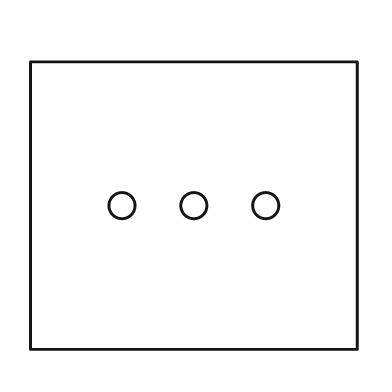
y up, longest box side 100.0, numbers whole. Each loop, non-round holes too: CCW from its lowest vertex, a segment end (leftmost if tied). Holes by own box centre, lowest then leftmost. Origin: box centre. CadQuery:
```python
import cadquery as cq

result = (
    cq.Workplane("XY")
    .moveTo(-50.0, -44.0)
    .lineTo(50.0, -44.0)
    .lineTo(50.0, 44.0)
    .lineTo(-50.0, 44.0)
    .close()
    .moveTo(-22.0, 0.0)
    .circle(4.0)
    .moveTo(0.0, 0.0)
    .circle(4.0)
    .moveTo(22.0, 0.0)
    .circle(4.0)
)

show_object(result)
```